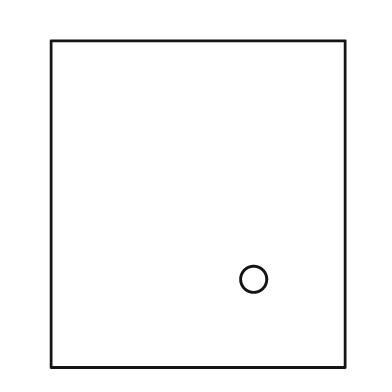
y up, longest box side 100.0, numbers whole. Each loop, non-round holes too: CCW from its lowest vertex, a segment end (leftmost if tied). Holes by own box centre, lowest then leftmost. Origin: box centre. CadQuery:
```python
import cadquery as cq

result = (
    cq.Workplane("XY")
    .moveTo(-45.0, -50.0)
    .lineTo(45.0, -50.0)
    .lineTo(45.0, 50.0)
    .lineTo(-45.0, 50.0)
    .close()
    .moveTo(17.0, -23.0)
    .circle(4.0)
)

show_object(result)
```